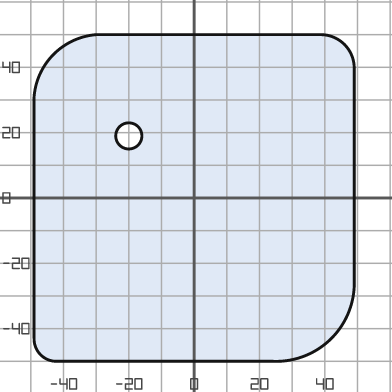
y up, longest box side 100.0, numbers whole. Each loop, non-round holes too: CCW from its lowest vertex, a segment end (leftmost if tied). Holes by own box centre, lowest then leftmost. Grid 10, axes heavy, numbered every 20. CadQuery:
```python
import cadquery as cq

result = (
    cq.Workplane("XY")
    .moveTo(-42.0, -50.0)
    .lineTo(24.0, -50.0)
    .threePointArc((42.0, -43.0), (49.0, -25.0))
    .lineTo(49.0, 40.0)
    .threePointArc((46.0, 47.0), (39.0, 50.0))
    .lineTo(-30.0, 50.0)
    .threePointArc((-43.0, 44.0), (-49.0, 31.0))
    .lineTo(-49.0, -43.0)
    .threePointArc((-47.0, -48.0), (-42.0, -50.0))
    .close()
    .moveTo(-20.0, 19.0)
    .circle(4.0)
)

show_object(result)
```